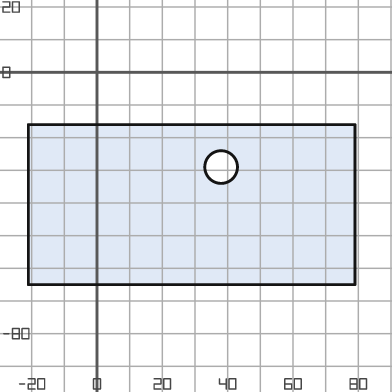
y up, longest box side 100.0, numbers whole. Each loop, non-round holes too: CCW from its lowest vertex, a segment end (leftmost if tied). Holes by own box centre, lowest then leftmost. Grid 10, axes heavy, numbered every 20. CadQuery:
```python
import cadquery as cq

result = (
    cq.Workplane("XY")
    .moveTo(-21.0, -65.0)
    .lineTo(79.0, -65.0)
    .lineTo(79.0, -16.0)
    .lineTo(-21.0, -16.0)
    .close()
    .moveTo(38.0, -29.0)
    .circle(5.0)
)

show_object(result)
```